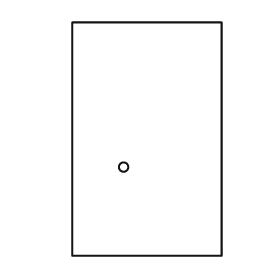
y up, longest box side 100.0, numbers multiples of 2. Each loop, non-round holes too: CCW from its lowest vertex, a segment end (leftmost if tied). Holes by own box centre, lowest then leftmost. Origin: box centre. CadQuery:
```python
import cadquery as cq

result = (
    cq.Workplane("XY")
    .moveTo(-32.0, -50.0)
    .lineTo(32.0, -50.0)
    .lineTo(32.0, 50.0)
    .lineTo(-32.0, 50.0)
    .close()
    .moveTo(-10.0, -12.0)
    .circle(2.0)
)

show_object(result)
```